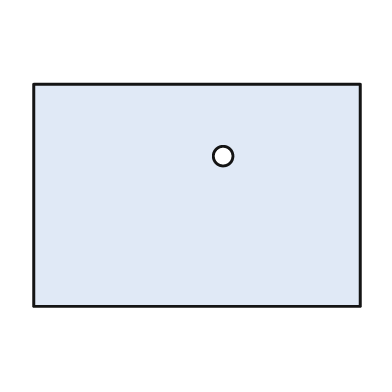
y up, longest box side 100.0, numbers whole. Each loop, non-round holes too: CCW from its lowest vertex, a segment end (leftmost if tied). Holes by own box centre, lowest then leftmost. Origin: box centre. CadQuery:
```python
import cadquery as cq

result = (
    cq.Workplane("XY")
    .moveTo(-50.0, -34.0)
    .lineTo(50.0, -34.0)
    .lineTo(50.0, 34.0)
    .lineTo(-50.0, 34.0)
    .close()
    .moveTo(8.0, 12.0)
    .circle(3.0)
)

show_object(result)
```